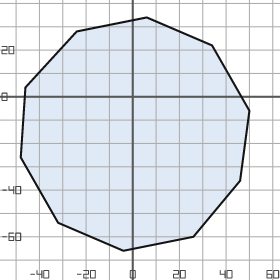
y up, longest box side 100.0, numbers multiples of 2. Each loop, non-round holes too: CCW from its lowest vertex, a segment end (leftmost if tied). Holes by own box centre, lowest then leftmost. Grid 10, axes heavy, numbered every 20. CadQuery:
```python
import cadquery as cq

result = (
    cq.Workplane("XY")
    .moveTo(-4.0, -66.0)
    .lineTo(26.0, -60.0)
    .lineTo(46.0, -36.0)
    .lineTo(50.0, -6.0)
    .lineTo(34.0, 22.0)
    .lineTo(6.0, 34.0)
    .lineTo(-24.0, 28.0)
    .lineTo(-46.0, 4.0)
    .lineTo(-48.0, -26.0)
    .lineTo(-32.0, -54.0)
    .close()
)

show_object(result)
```